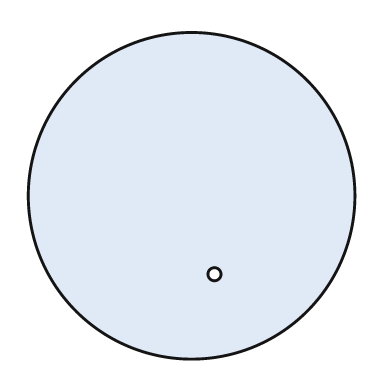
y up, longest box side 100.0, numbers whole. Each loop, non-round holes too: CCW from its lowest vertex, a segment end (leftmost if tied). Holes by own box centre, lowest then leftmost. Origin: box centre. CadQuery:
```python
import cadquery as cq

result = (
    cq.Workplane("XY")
    .moveTo(0.0, 0.0)
    .circle(50.0)
    .moveTo(7.0, -24.0)
    .circle(2.0)
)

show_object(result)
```